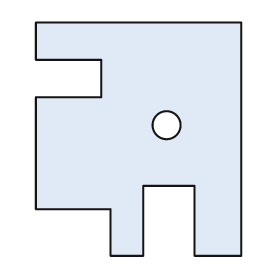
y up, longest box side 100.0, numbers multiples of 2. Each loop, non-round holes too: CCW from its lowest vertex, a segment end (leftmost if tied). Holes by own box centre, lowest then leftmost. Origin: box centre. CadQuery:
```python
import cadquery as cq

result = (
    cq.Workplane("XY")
    .moveTo(-12.0, -50.0)
    .lineTo(2.0, -50.0)
    .lineTo(2.0, -20.0)
    .lineTo(24.0, -20.0)
    .lineTo(24.0, -50.0)
    .lineTo(44.0, -50.0)
    .lineTo(44.0, 50.0)
    .lineTo(-44.0, 50.0)
    .lineTo(-44.0, 34.0)
    .lineTo(-16.0, 34.0)
    .lineTo(-16.0, 18.0)
    .lineTo(-44.0, 18.0)
    .lineTo(-44.0, -30.0)
    .lineTo(-12.0, -30.0)
    .close()
    .moveTo(12.0, 6.0)
    .circle(6.0)
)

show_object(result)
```